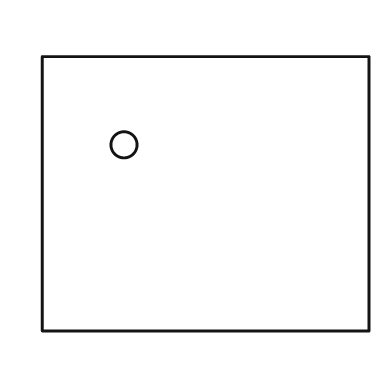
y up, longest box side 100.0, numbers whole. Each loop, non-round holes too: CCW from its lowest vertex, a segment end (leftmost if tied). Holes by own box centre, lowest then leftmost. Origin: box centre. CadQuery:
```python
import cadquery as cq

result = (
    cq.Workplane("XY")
    .moveTo(-50.0, -42.0)
    .lineTo(50.0, -42.0)
    .lineTo(50.0, 42.0)
    .lineTo(-50.0, 42.0)
    .close()
    .moveTo(-25.0, 15.0)
    .circle(4.0)
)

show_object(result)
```